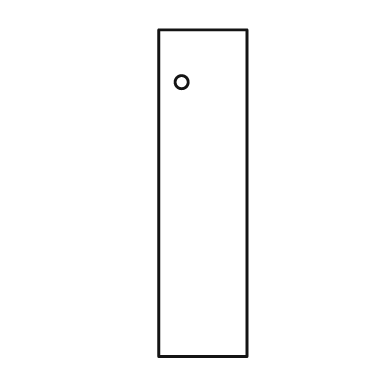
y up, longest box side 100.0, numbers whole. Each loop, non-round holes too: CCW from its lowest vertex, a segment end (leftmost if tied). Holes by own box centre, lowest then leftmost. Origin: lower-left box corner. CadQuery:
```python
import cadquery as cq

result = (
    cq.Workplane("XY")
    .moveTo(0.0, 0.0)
    .lineTo(27.0, 0.0)
    .lineTo(27.0, 100.0)
    .lineTo(0.0, 100.0)
    .close()
    .moveTo(7.0, 84.0)
    .circle(2.0)
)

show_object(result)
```